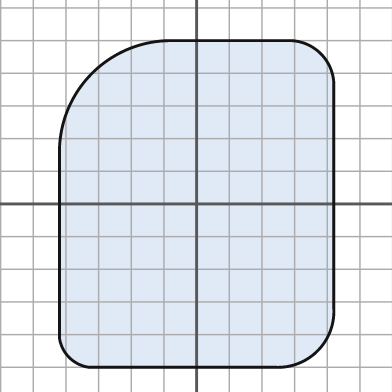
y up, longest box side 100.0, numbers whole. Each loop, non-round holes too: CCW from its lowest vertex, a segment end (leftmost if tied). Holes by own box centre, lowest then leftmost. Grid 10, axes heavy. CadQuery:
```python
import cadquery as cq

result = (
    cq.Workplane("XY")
    .moveTo(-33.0, -50.0)
    .lineTo(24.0, -50.0)
    .threePointArc((37.0, -45.0), (42.0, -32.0))
    .lineTo(42.0, 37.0)
    .threePointArc((38.0, 46.0), (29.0, 50.0))
    .lineTo(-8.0, 50.0)
    .threePointArc((-32.0, 40.0), (-42.0, 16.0))
    .lineTo(-42.0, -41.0)
    .threePointArc((-39.0, -47.0), (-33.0, -50.0))
    .close()
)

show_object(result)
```